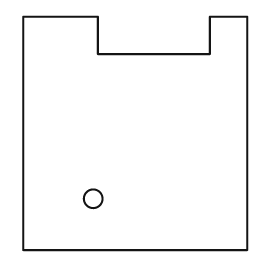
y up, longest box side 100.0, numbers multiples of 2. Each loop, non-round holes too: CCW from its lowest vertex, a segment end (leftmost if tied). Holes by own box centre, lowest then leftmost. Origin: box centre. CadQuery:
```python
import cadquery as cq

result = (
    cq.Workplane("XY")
    .moveTo(-48.0, -50.0)
    .lineTo(48.0, -50.0)
    .lineTo(48.0, 50.0)
    .lineTo(32.0, 50.0)
    .lineTo(32.0, 34.0)
    .lineTo(-16.0, 34.0)
    .lineTo(-16.0, 50.0)
    .lineTo(-48.0, 50.0)
    .close()
    .moveTo(-18.0, -28.0)
    .circle(4.0)
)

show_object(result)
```